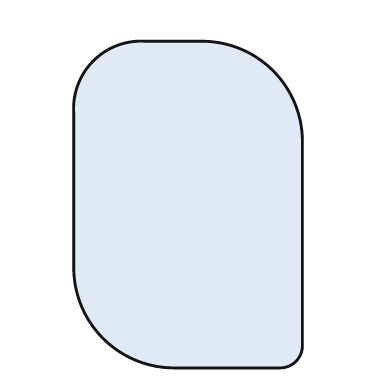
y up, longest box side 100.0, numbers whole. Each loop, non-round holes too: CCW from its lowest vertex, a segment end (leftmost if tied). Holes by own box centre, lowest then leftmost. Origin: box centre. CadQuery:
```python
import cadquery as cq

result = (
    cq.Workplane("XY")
    .moveTo(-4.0, -50.0)
    .lineTo(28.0, -50.0)
    .threePointArc((33.0, -48.0), (35.0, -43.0))
    .lineTo(35.0, 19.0)
    .threePointArc((26.0, 41.0), (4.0, 50.0))
    .lineTo(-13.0, 50.0)
    .threePointArc((-29.0, 44.0), (-35.0, 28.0))
    .lineTo(-35.0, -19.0)
    .threePointArc((-26.0, -41.0), (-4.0, -50.0))
    .close()
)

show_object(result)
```